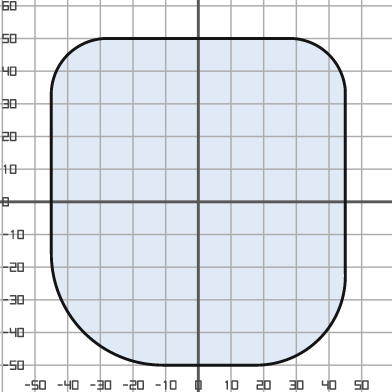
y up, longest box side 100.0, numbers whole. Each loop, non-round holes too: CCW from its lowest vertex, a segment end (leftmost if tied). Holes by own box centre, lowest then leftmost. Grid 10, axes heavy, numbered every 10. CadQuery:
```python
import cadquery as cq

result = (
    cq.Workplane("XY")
    .moveTo(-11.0, -50.0)
    .lineTo(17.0, -50.0)
    .threePointArc((37.0, -42.0), (45.0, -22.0))
    .lineTo(45.0, 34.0)
    .threePointArc((40.0, 45.0), (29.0, 50.0))
    .lineTo(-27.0, 50.0)
    .threePointArc((-40.0, 45.0), (-45.0, 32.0))
    .lineTo(-45.0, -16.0)
    .threePointArc((-35.0, -40.0), (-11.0, -50.0))
    .close()
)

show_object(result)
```